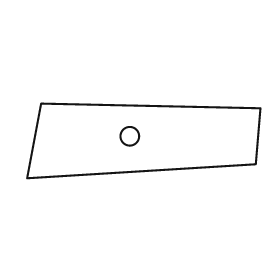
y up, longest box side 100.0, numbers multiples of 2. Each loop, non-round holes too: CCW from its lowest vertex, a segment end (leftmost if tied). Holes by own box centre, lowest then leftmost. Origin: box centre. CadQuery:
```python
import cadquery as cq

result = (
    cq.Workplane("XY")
    .moveTo(-50.0, -16.0)
    .lineTo(48.0, -10.0)
    .lineTo(50.0, 14.0)
    .lineTo(-44.0, 16.0)
    .close()
    .moveTo(-6.0, 2.0)
    .circle(4.0)
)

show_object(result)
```